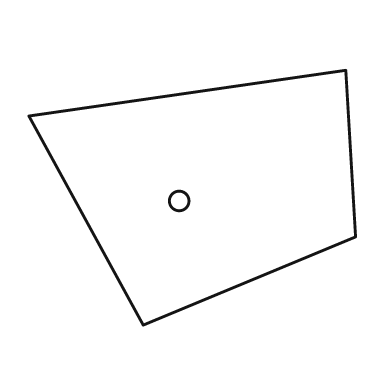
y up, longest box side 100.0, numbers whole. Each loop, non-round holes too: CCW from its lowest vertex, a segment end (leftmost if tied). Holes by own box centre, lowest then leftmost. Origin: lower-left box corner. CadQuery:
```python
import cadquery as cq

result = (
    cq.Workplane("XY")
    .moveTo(35.0, 0.0)
    .lineTo(100.0, 27.0)
    .lineTo(97.0, 78.0)
    .lineTo(0.0, 64.0)
    .close()
    .moveTo(46.0, 38.0)
    .circle(3.0)
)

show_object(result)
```